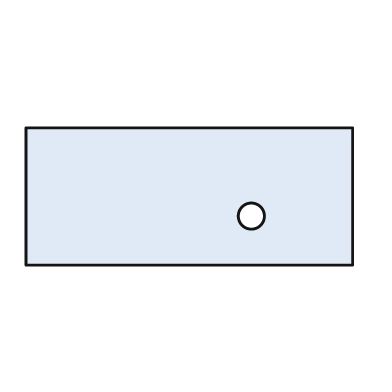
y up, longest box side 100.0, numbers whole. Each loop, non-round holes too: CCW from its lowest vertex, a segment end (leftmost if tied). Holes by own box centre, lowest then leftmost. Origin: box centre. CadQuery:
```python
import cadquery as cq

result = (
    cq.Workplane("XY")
    .moveTo(-50.0, -21.0)
    .lineTo(50.0, -21.0)
    .lineTo(50.0, 21.0)
    .lineTo(-50.0, 21.0)
    .close()
    .moveTo(19.0, -6.0)
    .circle(4.0)
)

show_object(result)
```